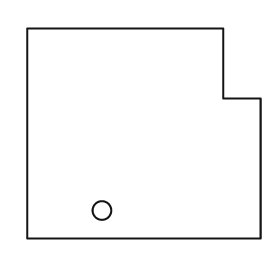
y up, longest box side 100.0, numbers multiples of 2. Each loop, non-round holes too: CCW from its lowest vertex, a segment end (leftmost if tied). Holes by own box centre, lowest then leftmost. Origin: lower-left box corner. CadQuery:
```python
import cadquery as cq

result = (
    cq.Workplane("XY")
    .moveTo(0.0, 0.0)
    .lineTo(100.0, 0.0)
    .lineTo(100.0, 60.0)
    .lineTo(84.0, 60.0)
    .lineTo(84.0, 90.0)
    .lineTo(0.0, 90.0)
    .close()
    .moveTo(32.0, 12.0)
    .circle(4.0)
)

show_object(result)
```